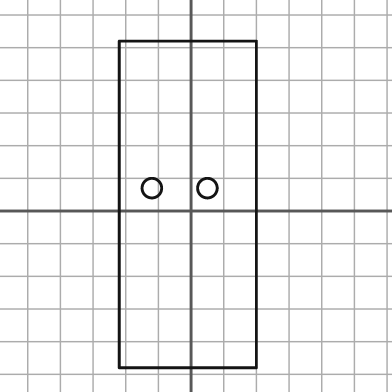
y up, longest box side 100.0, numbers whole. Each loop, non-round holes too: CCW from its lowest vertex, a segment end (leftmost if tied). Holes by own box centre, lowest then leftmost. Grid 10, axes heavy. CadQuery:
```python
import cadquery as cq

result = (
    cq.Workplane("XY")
    .moveTo(-22.0, -48.0)
    .lineTo(20.0, -48.0)
    .lineTo(20.0, 52.0)
    .lineTo(-22.0, 52.0)
    .close()
    .moveTo(-12.0, 7.0)
    .circle(3.0)
    .moveTo(5.0, 7.0)
    .circle(3.0)
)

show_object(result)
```